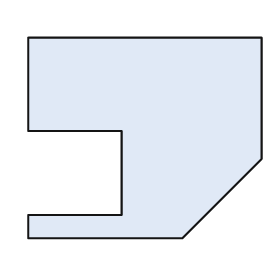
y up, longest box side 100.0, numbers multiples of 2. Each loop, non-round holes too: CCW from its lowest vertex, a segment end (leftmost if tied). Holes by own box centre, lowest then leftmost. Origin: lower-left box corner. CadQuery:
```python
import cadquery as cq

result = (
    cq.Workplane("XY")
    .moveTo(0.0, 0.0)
    .lineTo(66.0, 0.0)
    .lineTo(100.0, 34.0)
    .lineTo(100.0, 86.0)
    .lineTo(0.0, 86.0)
    .lineTo(0.0, 46.0)
    .lineTo(40.0, 46.0)
    .lineTo(40.0, 10.0)
    .lineTo(0.0, 10.0)
    .close()
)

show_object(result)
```